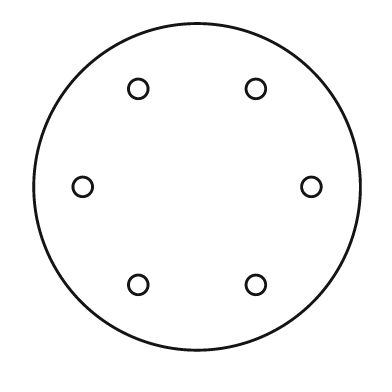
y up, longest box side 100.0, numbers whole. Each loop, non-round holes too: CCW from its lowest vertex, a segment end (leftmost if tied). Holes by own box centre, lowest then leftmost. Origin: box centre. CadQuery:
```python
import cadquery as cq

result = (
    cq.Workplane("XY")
    .moveTo(0.0, 0.0)
    .circle(50.0)
    .moveTo(-18.0, -30.0)
    .circle(3.0)
    .moveTo(18.0, -30.0)
    .circle(3.0)
    .moveTo(-35.0, 0.0)
    .circle(3.0)
    .moveTo(35.0, 0.0)
    .circle(3.0)
    .moveTo(-18.0, 30.0)
    .circle(3.0)
    .moveTo(18.0, 30.0)
    .circle(3.0)
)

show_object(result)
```